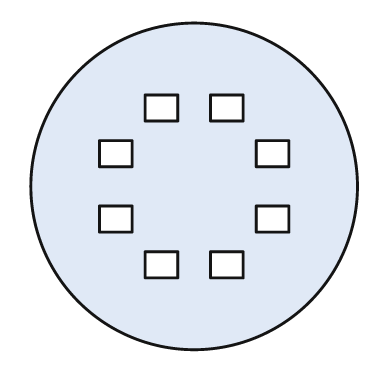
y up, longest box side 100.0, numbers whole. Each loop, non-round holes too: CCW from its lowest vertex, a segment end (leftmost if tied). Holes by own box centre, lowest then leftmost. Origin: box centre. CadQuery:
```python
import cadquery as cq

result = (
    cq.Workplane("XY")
    .moveTo(0.0, 0.0)
    .circle(50.0)
    .moveTo(-15.0, -28.0)
    .lineTo(-5.0, -28.0)
    .lineTo(-5.0, -20.0)
    .lineTo(-15.0, -20.0)
    .close()
    .moveTo(5.0, -28.0)
    .lineTo(15.0, -28.0)
    .lineTo(15.0, -20.0)
    .lineTo(5.0, -20.0)
    .close()
    .moveTo(-29.0, -14.0)
    .lineTo(-19.0, -14.0)
    .lineTo(-19.0, -6.0)
    .lineTo(-29.0, -6.0)
    .close()
    .moveTo(19.0, -14.0)
    .lineTo(29.0, -14.0)
    .lineTo(29.0, -6.0)
    .lineTo(19.0, -6.0)
    .close()
    .moveTo(-29.0, 6.0)
    .lineTo(-19.0, 6.0)
    .lineTo(-19.0, 14.0)
    .lineTo(-29.0, 14.0)
    .close()
    .moveTo(19.0, 6.0)
    .lineTo(29.0, 6.0)
    .lineTo(29.0, 14.0)
    .lineTo(19.0, 14.0)
    .close()
    .moveTo(-15.0, 20.0)
    .lineTo(-5.0, 20.0)
    .lineTo(-5.0, 28.0)
    .lineTo(-15.0, 28.0)
    .close()
    .moveTo(5.0, 20.0)
    .lineTo(15.0, 20.0)
    .lineTo(15.0, 28.0)
    .lineTo(5.0, 28.0)
    .close()
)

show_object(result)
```